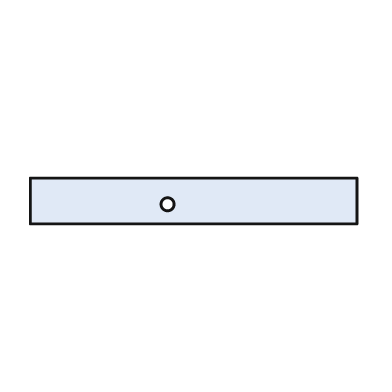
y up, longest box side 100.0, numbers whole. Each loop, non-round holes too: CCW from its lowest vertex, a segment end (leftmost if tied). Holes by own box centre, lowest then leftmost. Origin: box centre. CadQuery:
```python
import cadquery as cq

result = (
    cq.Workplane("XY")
    .moveTo(-50.0, -7.0)
    .lineTo(50.0, -7.0)
    .lineTo(50.0, 7.0)
    .lineTo(-50.0, 7.0)
    .close()
    .moveTo(-8.0, -1.0)
    .circle(2.0)
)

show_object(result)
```